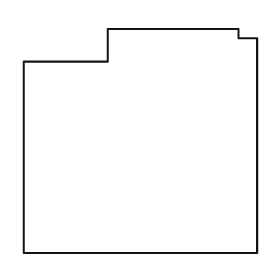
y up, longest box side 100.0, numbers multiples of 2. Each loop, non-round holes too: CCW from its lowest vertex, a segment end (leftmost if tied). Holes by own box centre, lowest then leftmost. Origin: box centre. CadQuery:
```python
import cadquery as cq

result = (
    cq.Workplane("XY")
    .moveTo(-50.0, -48.0)
    .lineTo(50.0, -48.0)
    .lineTo(50.0, 44.0)
    .lineTo(42.0, 44.0)
    .lineTo(42.0, 48.0)
    .lineTo(-14.0, 48.0)
    .lineTo(-14.0, 34.0)
    .lineTo(-50.0, 34.0)
    .close()
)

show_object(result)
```